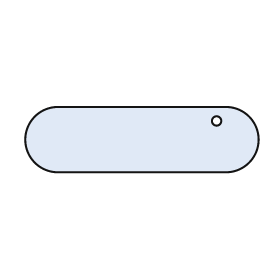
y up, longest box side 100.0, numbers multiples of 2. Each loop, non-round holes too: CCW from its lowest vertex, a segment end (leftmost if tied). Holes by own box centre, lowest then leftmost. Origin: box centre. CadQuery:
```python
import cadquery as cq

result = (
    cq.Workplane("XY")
    .moveTo(-36.0, -14.0)
    .lineTo(36.0, -14.0)
    .threePointArc((50.0, 0.0), (36.0, 14.0))
    .lineTo(-36.0, 14.0)
    .threePointArc((-50.0, 0.0), (-36.0, -14.0))
    .close()
    .moveTo(32.0, 8.0)
    .circle(2.0)
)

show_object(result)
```